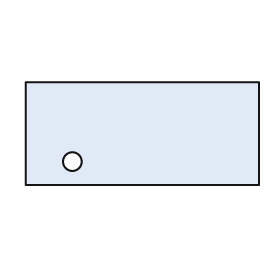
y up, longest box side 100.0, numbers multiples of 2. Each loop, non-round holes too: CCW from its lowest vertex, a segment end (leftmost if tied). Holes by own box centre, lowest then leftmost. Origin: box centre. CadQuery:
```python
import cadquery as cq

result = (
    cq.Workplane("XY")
    .moveTo(-50.0, -22.0)
    .lineTo(50.0, -22.0)
    .lineTo(50.0, 22.0)
    .lineTo(-50.0, 22.0)
    .close()
    .moveTo(-30.0, -12.0)
    .circle(4.0)
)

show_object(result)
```